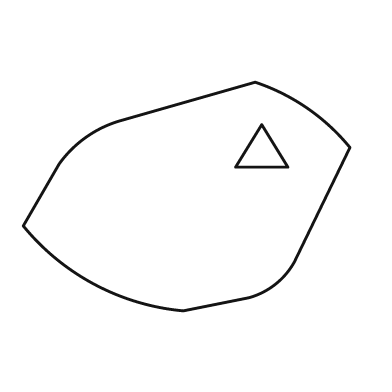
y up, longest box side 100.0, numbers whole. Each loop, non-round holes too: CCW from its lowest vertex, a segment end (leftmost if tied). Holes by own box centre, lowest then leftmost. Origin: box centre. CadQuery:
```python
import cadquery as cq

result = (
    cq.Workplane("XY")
    .moveTo(-1.0, -35.0)
    .lineTo(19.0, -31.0)
    .threePointArc((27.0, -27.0), (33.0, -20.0))
    .lineTo(50.0, 15.0)
    .threePointArc((37.0, 27.0), (21.0, 35.0))
    .lineTo(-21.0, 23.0)
    .threePointArc((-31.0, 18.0), (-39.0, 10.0))
    .lineTo(-50.0, -9.0)
    .threePointArc((-28.0, -27.0), (-1.0, -35.0))
    .close()
    .moveTo(15.0, 9.0)
    .lineTo(31.0, 9.0)
    .lineTo(23.0, 22.0)
    .close()
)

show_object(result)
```